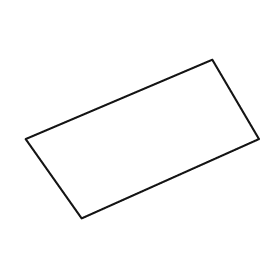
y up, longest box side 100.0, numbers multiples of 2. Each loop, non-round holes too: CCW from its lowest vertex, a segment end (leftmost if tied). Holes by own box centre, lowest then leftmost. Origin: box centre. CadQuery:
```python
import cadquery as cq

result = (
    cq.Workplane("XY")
    .moveTo(-26.0, -34.0)
    .lineTo(50.0, 0.0)
    .lineTo(30.0, 34.0)
    .lineTo(-50.0, 0.0)
    .close()
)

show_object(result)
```